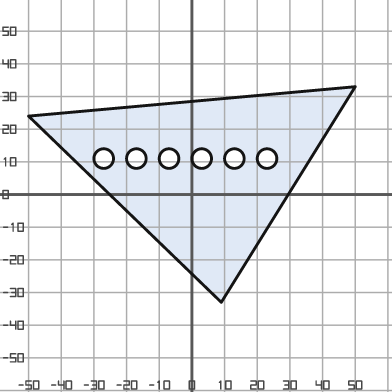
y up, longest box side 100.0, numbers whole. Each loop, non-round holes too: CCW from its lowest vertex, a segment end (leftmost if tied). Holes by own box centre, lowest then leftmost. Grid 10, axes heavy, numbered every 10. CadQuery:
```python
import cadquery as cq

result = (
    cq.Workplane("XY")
    .moveTo(9.0, -33.0)
    .lineTo(50.0, 33.0)
    .lineTo(-50.0, 24.0)
    .close()
    .moveTo(-27.0, 11.0)
    .circle(3.0)
    .moveTo(-17.0, 11.0)
    .circle(3.0)
    .moveTo(-7.0, 11.0)
    .circle(3.0)
    .moveTo(3.0, 11.0)
    .circle(3.0)
    .moveTo(13.0, 11.0)
    .circle(3.0)
    .moveTo(23.0, 11.0)
    .circle(3.0)
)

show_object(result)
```